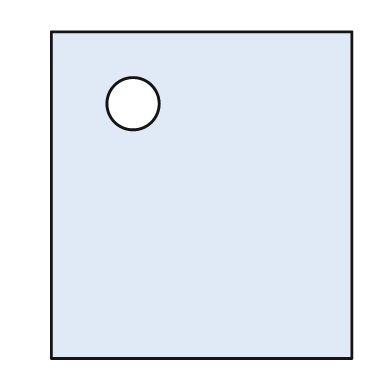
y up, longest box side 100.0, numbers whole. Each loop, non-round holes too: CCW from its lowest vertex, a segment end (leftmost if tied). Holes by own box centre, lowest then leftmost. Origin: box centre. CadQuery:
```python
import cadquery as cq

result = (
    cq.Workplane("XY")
    .moveTo(-46.0, -50.0)
    .lineTo(46.0, -50.0)
    .lineTo(46.0, 50.0)
    .lineTo(-46.0, 50.0)
    .close()
    .moveTo(-21.0, 28.0)
    .circle(8.0)
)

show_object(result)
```